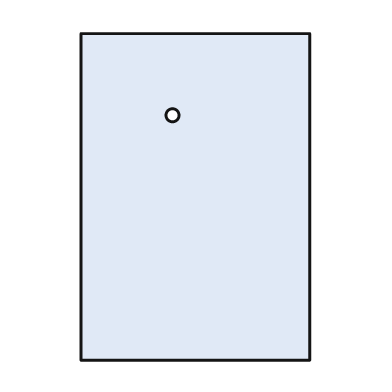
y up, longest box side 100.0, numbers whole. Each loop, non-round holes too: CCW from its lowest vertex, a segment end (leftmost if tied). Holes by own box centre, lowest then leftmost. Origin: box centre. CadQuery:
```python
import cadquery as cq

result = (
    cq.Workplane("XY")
    .moveTo(-35.0, -50.0)
    .lineTo(35.0, -50.0)
    .lineTo(35.0, 50.0)
    .lineTo(-35.0, 50.0)
    .close()
    .moveTo(-7.0, 25.0)
    .circle(2.0)
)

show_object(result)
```